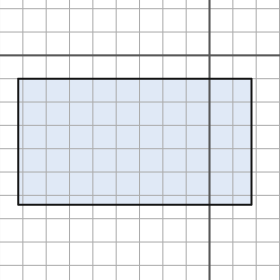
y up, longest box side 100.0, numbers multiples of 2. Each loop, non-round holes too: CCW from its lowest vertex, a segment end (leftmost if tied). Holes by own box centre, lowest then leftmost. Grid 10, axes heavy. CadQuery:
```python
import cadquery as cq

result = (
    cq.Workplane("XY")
    .moveTo(-82.0, -64.0)
    .lineTo(18.0, -64.0)
    .lineTo(18.0, -10.0)
    .lineTo(-82.0, -10.0)
    .close()
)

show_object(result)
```